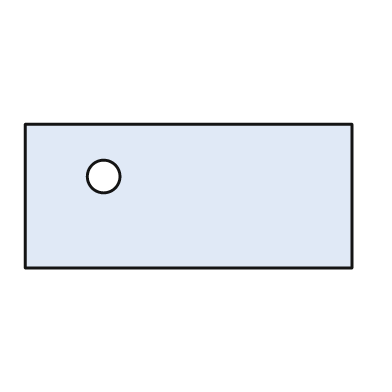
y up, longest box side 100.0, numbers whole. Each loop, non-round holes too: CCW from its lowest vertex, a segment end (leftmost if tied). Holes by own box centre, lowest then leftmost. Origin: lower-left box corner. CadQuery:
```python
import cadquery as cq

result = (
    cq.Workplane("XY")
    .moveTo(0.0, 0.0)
    .lineTo(100.0, 0.0)
    .lineTo(100.0, 44.0)
    .lineTo(0.0, 44.0)
    .close()
    .moveTo(24.0, 28.0)
    .circle(5.0)
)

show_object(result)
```